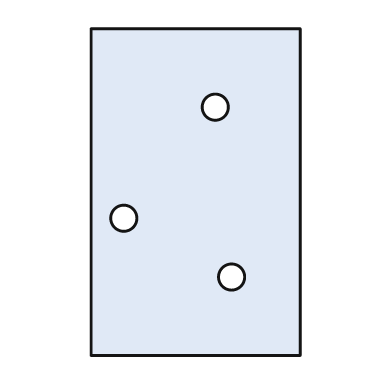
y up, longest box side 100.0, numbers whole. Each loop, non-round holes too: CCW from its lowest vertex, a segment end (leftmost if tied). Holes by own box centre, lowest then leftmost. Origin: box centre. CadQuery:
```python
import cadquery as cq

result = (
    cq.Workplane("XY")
    .moveTo(-32.0, -50.0)
    .lineTo(32.0, -50.0)
    .lineTo(32.0, 50.0)
    .lineTo(-32.0, 50.0)
    .close()
    .moveTo(11.0, -26.0)
    .circle(4.0)
    .moveTo(-22.0, -8.0)
    .circle(4.0)
    .moveTo(6.0, 26.0)
    .circle(4.0)
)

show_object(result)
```